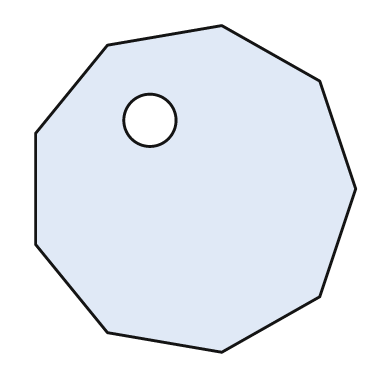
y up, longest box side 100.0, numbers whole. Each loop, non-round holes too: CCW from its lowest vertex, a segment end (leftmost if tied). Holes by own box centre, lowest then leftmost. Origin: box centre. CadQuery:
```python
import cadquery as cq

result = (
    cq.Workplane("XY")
    .moveTo(8.0, -50.0)
    .lineTo(38.0, -33.0)
    .lineTo(49.0, 0.0)
    .lineTo(38.0, 33.0)
    .lineTo(8.0, 50.0)
    .lineTo(-27.0, 44.0)
    .lineTo(-49.0, 17.0)
    .lineTo(-49.0, -17.0)
    .lineTo(-27.0, -44.0)
    .close()
    .moveTo(-14.0, 21.0)
    .circle(8.0)
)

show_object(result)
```